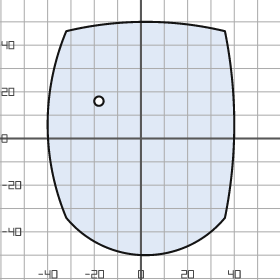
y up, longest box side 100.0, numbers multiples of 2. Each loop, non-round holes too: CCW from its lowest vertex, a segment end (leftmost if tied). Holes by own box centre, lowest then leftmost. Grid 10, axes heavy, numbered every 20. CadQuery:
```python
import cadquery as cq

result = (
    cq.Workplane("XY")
    .moveTo(-32.0, -34.0)
    .threePointArc((2.0, -50.0), (36.0, -34.0))
    .threePointArc((40.0, 6.0), (36.0, 46.0))
    .threePointArc((2.0, 50.0), (-32.0, 46.0))
    .threePointArc((-40.0, 6.0), (-32.0, -34.0))
    .close()
    .moveTo(-18.0, 16.0)
    .circle(2.0)
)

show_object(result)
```